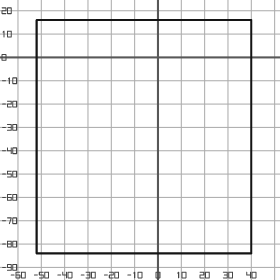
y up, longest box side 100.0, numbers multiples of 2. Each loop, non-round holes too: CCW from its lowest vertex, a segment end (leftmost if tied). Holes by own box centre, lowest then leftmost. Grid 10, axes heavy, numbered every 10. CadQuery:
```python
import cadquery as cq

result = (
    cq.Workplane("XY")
    .moveTo(-52.0, -84.0)
    .lineTo(40.0, -84.0)
    .lineTo(40.0, 16.0)
    .lineTo(-52.0, 16.0)
    .close()
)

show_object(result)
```